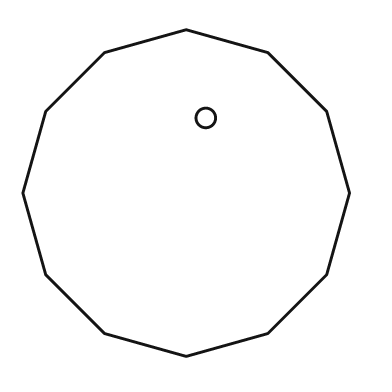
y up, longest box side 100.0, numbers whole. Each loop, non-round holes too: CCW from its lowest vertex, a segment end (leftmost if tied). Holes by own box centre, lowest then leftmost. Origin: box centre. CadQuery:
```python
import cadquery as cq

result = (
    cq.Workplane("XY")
    .moveTo(0.0, -50.0)
    .lineTo(25.0, -43.0)
    .lineTo(43.0, -25.0)
    .lineTo(50.0, 0.0)
    .lineTo(43.0, 25.0)
    .lineTo(25.0, 43.0)
    .lineTo(0.0, 50.0)
    .lineTo(-25.0, 43.0)
    .lineTo(-43.0, 25.0)
    .lineTo(-50.0, 0.0)
    .lineTo(-43.0, -25.0)
    .lineTo(-25.0, -43.0)
    .close()
    .moveTo(6.0, 23.0)
    .circle(3.0)
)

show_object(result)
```